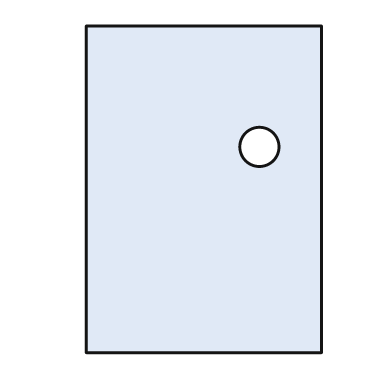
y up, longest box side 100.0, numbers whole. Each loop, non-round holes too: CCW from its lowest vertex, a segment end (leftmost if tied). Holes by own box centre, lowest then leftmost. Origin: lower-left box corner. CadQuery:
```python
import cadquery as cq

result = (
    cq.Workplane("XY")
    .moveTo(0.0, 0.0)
    .lineTo(72.0, 0.0)
    .lineTo(72.0, 100.0)
    .lineTo(0.0, 100.0)
    .close()
    .moveTo(53.0, 63.0)
    .circle(6.0)
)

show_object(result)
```